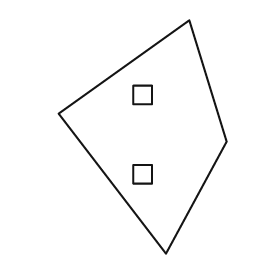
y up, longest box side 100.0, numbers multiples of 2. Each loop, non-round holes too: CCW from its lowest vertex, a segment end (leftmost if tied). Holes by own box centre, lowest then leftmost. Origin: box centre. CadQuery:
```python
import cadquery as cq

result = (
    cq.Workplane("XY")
    .moveTo(10.0, -50.0)
    .lineTo(36.0, -2.0)
    .lineTo(20.0, 50.0)
    .lineTo(-36.0, 10.0)
    .close()
    .moveTo(-4.0, -20.0)
    .lineTo(4.0, -20.0)
    .lineTo(4.0, -12.0)
    .lineTo(-4.0, -12.0)
    .close()
    .moveTo(-4.0, 14.0)
    .lineTo(4.0, 14.0)
    .lineTo(4.0, 22.0)
    .lineTo(-4.0, 22.0)
    .close()
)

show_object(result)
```